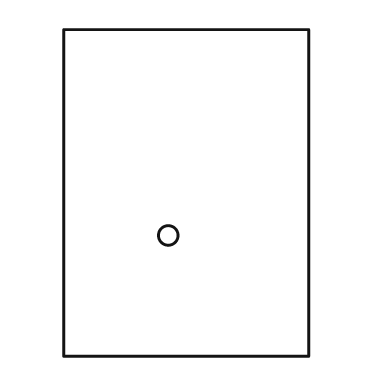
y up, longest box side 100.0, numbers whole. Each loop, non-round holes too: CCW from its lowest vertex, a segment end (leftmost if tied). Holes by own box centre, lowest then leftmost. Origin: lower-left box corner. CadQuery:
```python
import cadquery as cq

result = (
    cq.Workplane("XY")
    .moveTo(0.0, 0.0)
    .lineTo(75.0, 0.0)
    .lineTo(75.0, 100.0)
    .lineTo(0.0, 100.0)
    .close()
    .moveTo(32.0, 37.0)
    .circle(3.0)
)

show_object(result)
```